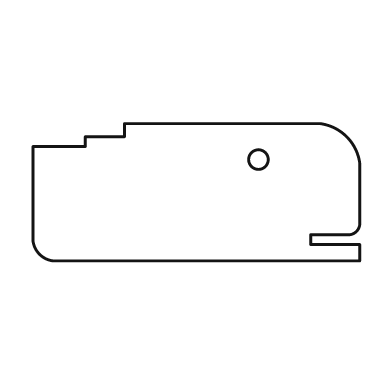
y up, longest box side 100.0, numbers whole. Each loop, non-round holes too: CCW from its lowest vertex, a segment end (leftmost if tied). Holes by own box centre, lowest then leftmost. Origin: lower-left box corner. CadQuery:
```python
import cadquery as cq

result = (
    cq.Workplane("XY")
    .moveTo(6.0, 0.0)
    .lineTo(100.0, 0.0)
    .lineTo(100.0, 5.0)
    .lineTo(85.0, 5.0)
    .lineTo(85.0, 8.0)
    .lineTo(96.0, 8.0)
    .threePointArc((99.0, 9.0), (100.0, 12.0))
    .lineTo(100.0, 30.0)
    .threePointArc((96.0, 38.0), (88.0, 42.0))
    .lineTo(28.0, 42.0)
    .lineTo(28.0, 38.0)
    .lineTo(16.0, 38.0)
    .lineTo(16.0, 35.0)
    .lineTo(0.0, 35.0)
    .lineTo(0.0, 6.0)
    .threePointArc((2.0, 2.0), (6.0, 0.0))
    .close()
    .moveTo(69.0, 31.0)
    .circle(3.0)
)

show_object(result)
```